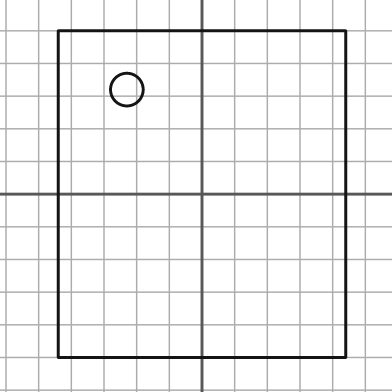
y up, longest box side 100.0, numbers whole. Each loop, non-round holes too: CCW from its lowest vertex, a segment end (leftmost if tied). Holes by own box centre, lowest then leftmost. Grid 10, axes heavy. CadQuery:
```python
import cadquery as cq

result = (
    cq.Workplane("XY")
    .moveTo(-44.0, -50.0)
    .lineTo(44.0, -50.0)
    .lineTo(44.0, 50.0)
    .lineTo(-44.0, 50.0)
    .close()
    .moveTo(-23.0, 32.0)
    .circle(5.0)
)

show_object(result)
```